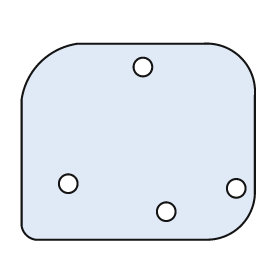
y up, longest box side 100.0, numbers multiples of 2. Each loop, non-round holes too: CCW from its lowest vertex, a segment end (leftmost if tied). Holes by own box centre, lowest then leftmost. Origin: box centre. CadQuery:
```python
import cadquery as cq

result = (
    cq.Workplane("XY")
    .moveTo(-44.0, -42.0)
    .lineTo(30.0, -42.0)
    .threePointArc((44.0, -36.0), (50.0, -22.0))
    .lineTo(50.0, 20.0)
    .threePointArc((44.0, 36.0), (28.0, 42.0))
    .lineTo(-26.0, 42.0)
    .threePointArc((-42.0, 34.0), (-50.0, 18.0))
    .lineTo(-50.0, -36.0)
    .threePointArc((-48.0, -40.0), (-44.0, -42.0))
    .close()
    .moveTo(12.0, -30.0)
    .circle(4.0)
    .moveTo(42.0, -20.0)
    .circle(4.0)
    .moveTo(-30.0, -18.0)
    .circle(4.0)
    .moveTo(2.0, 32.0)
    .circle(4.0)
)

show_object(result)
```